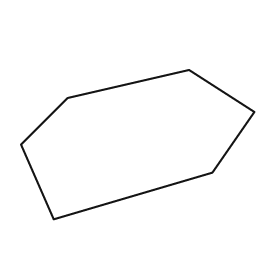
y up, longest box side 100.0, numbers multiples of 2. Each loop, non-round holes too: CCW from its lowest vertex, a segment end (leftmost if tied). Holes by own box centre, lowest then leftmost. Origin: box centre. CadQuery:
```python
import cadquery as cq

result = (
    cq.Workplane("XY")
    .moveTo(-36.0, -32.0)
    .lineTo(32.0, -12.0)
    .lineTo(50.0, 14.0)
    .lineTo(22.0, 32.0)
    .lineTo(-30.0, 20.0)
    .lineTo(-50.0, 0.0)
    .close()
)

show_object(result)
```